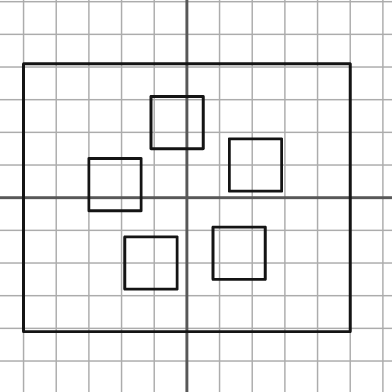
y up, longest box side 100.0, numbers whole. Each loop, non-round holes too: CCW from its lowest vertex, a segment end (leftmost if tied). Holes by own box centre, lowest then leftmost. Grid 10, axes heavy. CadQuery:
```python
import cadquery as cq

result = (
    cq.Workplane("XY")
    .moveTo(-50.0, -41.0)
    .lineTo(50.0, -41.0)
    .lineTo(50.0, 41.0)
    .lineTo(-50.0, 41.0)
    .close()
    .moveTo(-19.0, -28.0)
    .lineTo(-3.0, -28.0)
    .lineTo(-3.0, -12.0)
    .lineTo(-19.0, -12.0)
    .close()
    .moveTo(8.0, -25.0)
    .lineTo(24.0, -25.0)
    .lineTo(24.0, -9.0)
    .lineTo(8.0, -9.0)
    .close()
    .moveTo(-30.0, -4.0)
    .lineTo(-14.0, -4.0)
    .lineTo(-14.0, 12.0)
    .lineTo(-30.0, 12.0)
    .close()
    .moveTo(13.0, 2.0)
    .lineTo(29.0, 2.0)
    .lineTo(29.0, 18.0)
    .lineTo(13.0, 18.0)
    .close()
    .moveTo(-11.0, 15.0)
    .lineTo(5.0, 15.0)
    .lineTo(5.0, 31.0)
    .lineTo(-11.0, 31.0)
    .close()
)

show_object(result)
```